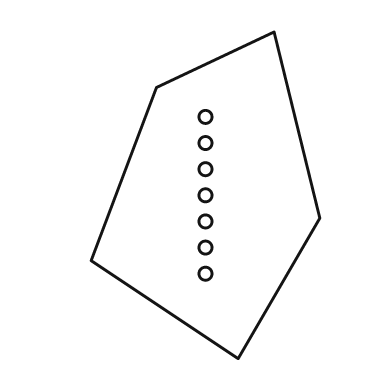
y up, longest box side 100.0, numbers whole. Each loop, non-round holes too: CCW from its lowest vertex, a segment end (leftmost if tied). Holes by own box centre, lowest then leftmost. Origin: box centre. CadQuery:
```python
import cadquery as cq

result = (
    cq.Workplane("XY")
    .moveTo(10.0, -50.0)
    .lineTo(35.0, -7.0)
    .lineTo(21.0, 50.0)
    .lineTo(-15.0, 33.0)
    .lineTo(-35.0, -20.0)
    .close()
    .moveTo(0.0, -24.0)
    .circle(2.0)
    .moveTo(0.0, -16.0)
    .circle(2.0)
    .moveTo(0.0, -8.0)
    .circle(2.0)
    .moveTo(0.0, 0.0)
    .circle(2.0)
    .moveTo(0.0, 8.0)
    .circle(2.0)
    .moveTo(0.0, 16.0)
    .circle(2.0)
    .moveTo(0.0, 24.0)
    .circle(2.0)
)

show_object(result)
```